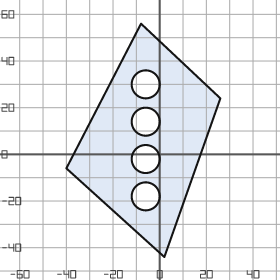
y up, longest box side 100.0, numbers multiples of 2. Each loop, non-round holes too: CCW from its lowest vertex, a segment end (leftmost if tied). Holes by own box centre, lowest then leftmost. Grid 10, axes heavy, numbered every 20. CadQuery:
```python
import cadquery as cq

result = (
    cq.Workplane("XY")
    .moveTo(2.0, -44.0)
    .lineTo(26.0, 24.0)
    .lineTo(-8.0, 56.0)
    .lineTo(-40.0, -6.0)
    .close()
    .moveTo(-6.0, -18.0)
    .circle(6.0)
    .moveTo(-6.0, -2.0)
    .circle(6.0)
    .moveTo(-6.0, 14.0)
    .circle(6.0)
    .moveTo(-6.0, 30.0)
    .circle(6.0)
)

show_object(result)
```